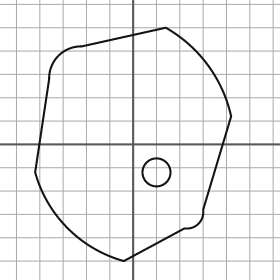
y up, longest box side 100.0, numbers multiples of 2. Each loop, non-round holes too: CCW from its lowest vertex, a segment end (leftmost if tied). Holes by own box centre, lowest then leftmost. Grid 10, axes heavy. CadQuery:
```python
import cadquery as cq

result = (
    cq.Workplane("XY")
    .moveTo(-4.0, -50.0)
    .lineTo(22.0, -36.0)
    .threePointArc((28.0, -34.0), (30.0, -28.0))
    .lineTo(42.0, 12.0)
    .threePointArc((32.0, 34.0), (14.0, 50.0))
    .lineTo(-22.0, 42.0)
    .threePointArc((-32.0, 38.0), (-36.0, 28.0))
    .lineTo(-42.0, -12.0)
    .threePointArc((-28.0, -36.0), (-4.0, -50.0))
    .close()
    .moveTo(10.0, -12.0)
    .circle(6.0)
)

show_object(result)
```